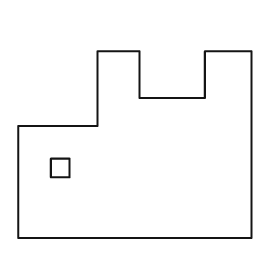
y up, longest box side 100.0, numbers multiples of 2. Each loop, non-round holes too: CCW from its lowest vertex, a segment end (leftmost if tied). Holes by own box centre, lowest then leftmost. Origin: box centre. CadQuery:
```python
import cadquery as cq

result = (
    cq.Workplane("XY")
    .moveTo(-50.0, -40.0)
    .lineTo(50.0, -40.0)
    .lineTo(50.0, 40.0)
    .lineTo(30.0, 40.0)
    .lineTo(30.0, 20.0)
    .lineTo(2.0, 20.0)
    .lineTo(2.0, 40.0)
    .lineTo(-16.0, 40.0)
    .lineTo(-16.0, 8.0)
    .lineTo(-50.0, 8.0)
    .close()
    .moveTo(-36.0, -14.0)
    .lineTo(-28.0, -14.0)
    .lineTo(-28.0, -6.0)
    .lineTo(-36.0, -6.0)
    .close()
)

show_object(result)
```